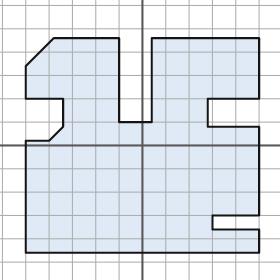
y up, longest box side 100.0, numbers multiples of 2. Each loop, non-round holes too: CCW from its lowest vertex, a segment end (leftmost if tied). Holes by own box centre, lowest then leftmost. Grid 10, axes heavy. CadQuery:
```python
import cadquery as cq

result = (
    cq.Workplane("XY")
    .moveTo(-50.0, -46.0)
    .lineTo(50.0, -46.0)
    .lineTo(50.0, -36.0)
    .lineTo(30.0, -36.0)
    .lineTo(30.0, -30.0)
    .lineTo(50.0, -30.0)
    .lineTo(50.0, 8.0)
    .lineTo(28.0, 8.0)
    .lineTo(28.0, 20.0)
    .lineTo(50.0, 20.0)
    .lineTo(50.0, 46.0)
    .lineTo(4.0, 46.0)
    .lineTo(4.0, 10.0)
    .lineTo(-10.0, 10.0)
    .lineTo(-10.0, 46.0)
    .lineTo(-38.0, 46.0)
    .lineTo(-50.0, 34.0)
    .lineTo(-50.0, 20.0)
    .lineTo(-34.0, 20.0)
    .lineTo(-34.0, 8.0)
    .lineTo(-40.0, 2.0)
    .lineTo(-50.0, 2.0)
    .close()
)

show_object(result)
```